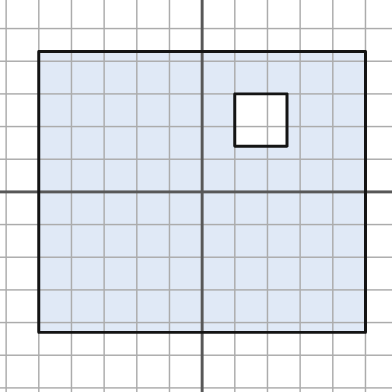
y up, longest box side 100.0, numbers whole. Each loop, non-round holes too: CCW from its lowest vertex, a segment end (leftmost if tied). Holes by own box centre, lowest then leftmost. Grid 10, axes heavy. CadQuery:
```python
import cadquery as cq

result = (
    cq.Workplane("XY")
    .moveTo(-50.0, -43.0)
    .lineTo(50.0, -43.0)
    .lineTo(50.0, 43.0)
    .lineTo(-50.0, 43.0)
    .close()
    .moveTo(10.0, 14.0)
    .lineTo(26.0, 14.0)
    .lineTo(26.0, 30.0)
    .lineTo(10.0, 30.0)
    .close()
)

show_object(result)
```